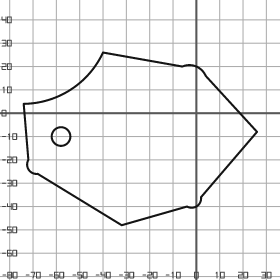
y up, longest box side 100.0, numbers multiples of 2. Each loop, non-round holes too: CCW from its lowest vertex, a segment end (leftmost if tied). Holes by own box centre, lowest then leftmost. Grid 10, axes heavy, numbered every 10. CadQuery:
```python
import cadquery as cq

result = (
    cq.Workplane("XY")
    .moveTo(-32.0, -48.0)
    .lineTo(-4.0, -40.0)
    .threePointArc((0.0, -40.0), (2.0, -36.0))
    .lineTo(26.0, -8.0)
    .lineTo(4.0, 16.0)
    .threePointArc((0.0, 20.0), (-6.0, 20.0))
    .lineTo(-40.0, 26.0)
    .threePointArc((-54.0, 10.0), (-74.0, 4.0))
    .lineTo(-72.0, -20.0)
    .threePointArc((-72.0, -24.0), (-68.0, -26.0))
    .close()
    .moveTo(-58.0, -10.0)
    .circle(4.0)
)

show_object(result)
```